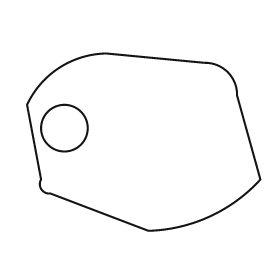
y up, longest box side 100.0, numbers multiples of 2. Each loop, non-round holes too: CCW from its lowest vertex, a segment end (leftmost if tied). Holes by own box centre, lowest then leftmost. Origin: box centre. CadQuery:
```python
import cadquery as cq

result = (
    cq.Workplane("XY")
    .moveTo(2.0, -38.0)
    .threePointArc((28.0, -32.0), (50.0, -16.0))
    .lineTo(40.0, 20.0)
    .threePointArc((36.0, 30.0), (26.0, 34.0))
    .lineTo(-16.0, 38.0)
    .threePointArc((-36.0, 32.0), (-50.0, 16.0))
    .lineTo(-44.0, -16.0)
    .threePointArc((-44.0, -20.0), (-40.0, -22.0))
    .close()
    .moveTo(-34.0, 6.0)
    .circle(10.0)
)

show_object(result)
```